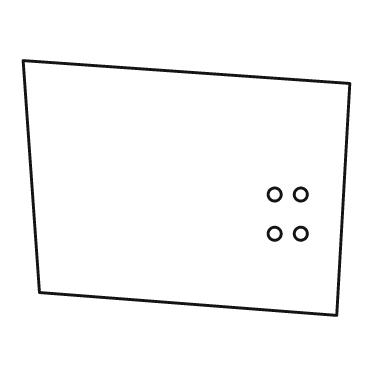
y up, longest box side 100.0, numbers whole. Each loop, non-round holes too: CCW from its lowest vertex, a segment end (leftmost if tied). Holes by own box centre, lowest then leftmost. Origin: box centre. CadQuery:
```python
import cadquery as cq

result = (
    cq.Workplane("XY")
    .moveTo(46.0, -39.0)
    .lineTo(50.0, 32.0)
    .lineTo(-50.0, 39.0)
    .lineTo(-45.0, -32.0)
    .close()
    .moveTo(27.0, -14.0)
    .circle(2.0)
    .moveTo(35.0, -14.0)
    .circle(2.0)
    .moveTo(27.0, -2.0)
    .circle(2.0)
    .moveTo(35.0, -2.0)
    .circle(2.0)
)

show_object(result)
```